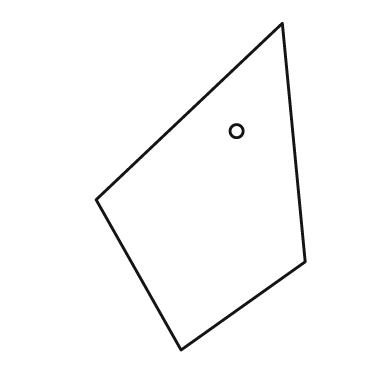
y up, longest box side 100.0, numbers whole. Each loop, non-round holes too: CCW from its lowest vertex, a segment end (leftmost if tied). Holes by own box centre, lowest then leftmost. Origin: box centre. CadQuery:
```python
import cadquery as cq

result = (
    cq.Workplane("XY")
    .moveTo(-6.0, -50.0)
    .lineTo(32.0, -23.0)
    .lineTo(25.0, 50.0)
    .lineTo(-32.0, -4.0)
    .close()
    .moveTo(11.0, 17.0)
    .circle(2.0)
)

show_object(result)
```